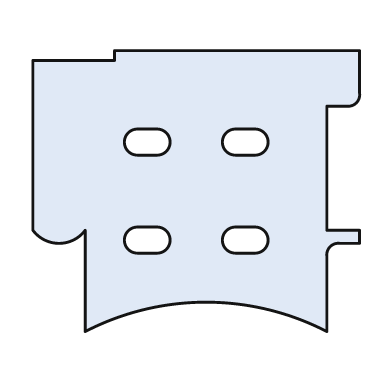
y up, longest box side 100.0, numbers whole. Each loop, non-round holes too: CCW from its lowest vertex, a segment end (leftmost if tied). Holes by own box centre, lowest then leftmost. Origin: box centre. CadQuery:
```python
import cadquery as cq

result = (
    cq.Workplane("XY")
    .moveTo(-34.0, -43.0)
    .threePointArc((3.0, -34.0), (40.0, -43.0))
    .lineTo(40.0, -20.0)
    .threePointArc((41.0, -17.0), (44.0, -16.0))
    .lineTo(50.0, -16.0)
    .lineTo(50.0, -12.0)
    .lineTo(40.0, -12.0)
    .lineTo(40.0, 26.0)
    .lineTo(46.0, 26.0)
    .threePointArc((49.0, 27.0), (50.0, 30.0))
    .lineTo(50.0, 43.0)
    .lineTo(-25.0, 43.0)
    .lineTo(-25.0, 40.0)
    .lineTo(-50.0, 40.0)
    .lineTo(-50.0, -12.0)
    .threePointArc((-42.0, -16.0), (-34.0, -12.0))
    .close()
    .moveTo(-18.0, -19.0)
    .lineTo(-12.0, -19.0)
    .threePointArc((-8.0, -15.0), (-12.0, -11.0))
    .lineTo(-18.0, -11.0)
    .threePointArc((-22.0, -15.0), (-18.0, -19.0))
    .close()
    .moveTo(12.0, -19.0)
    .lineTo(18.0, -19.0)
    .threePointArc((22.0, -15.0), (18.0, -11.0))
    .lineTo(12.0, -11.0)
    .threePointArc((8.0, -15.0), (12.0, -19.0))
    .close()
    .moveTo(-18.0, 11.0)
    .lineTo(-12.0, 11.0)
    .threePointArc((-8.0, 15.0), (-12.0, 19.0))
    .lineTo(-18.0, 19.0)
    .threePointArc((-22.0, 15.0), (-18.0, 11.0))
    .close()
    .moveTo(12.0, 11.0)
    .lineTo(18.0, 11.0)
    .threePointArc((22.0, 15.0), (18.0, 19.0))
    .lineTo(12.0, 19.0)
    .threePointArc((8.0, 15.0), (12.0, 11.0))
    .close()
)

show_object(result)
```